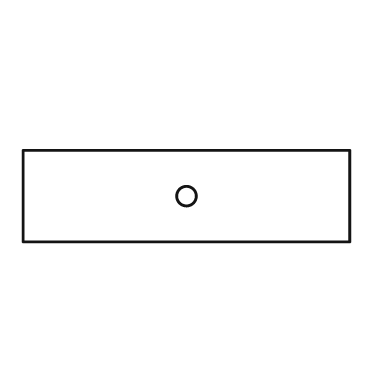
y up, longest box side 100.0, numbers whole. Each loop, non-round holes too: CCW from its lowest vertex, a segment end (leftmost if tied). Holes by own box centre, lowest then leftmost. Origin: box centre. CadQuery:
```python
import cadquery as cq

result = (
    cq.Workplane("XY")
    .moveTo(-50.0, -14.0)
    .lineTo(50.0, -14.0)
    .lineTo(50.0, 14.0)
    .lineTo(-50.0, 14.0)
    .close()
    .moveTo(0.0, 0.0)
    .circle(3.0)
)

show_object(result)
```